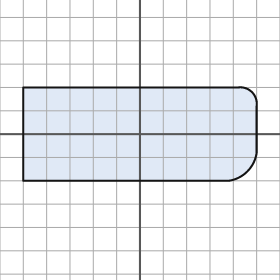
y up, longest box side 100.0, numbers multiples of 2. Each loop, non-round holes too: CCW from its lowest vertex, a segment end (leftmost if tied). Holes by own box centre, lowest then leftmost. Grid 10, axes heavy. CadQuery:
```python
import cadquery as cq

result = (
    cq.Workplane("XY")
    .moveTo(-50.0, -20.0)
    .lineTo(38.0, -20.0)
    .threePointArc((46.0, -16.0), (50.0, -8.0))
    .lineTo(50.0, 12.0)
    .threePointArc((48.0, 18.0), (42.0, 20.0))
    .lineTo(-50.0, 20.0)
    .close()
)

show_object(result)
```